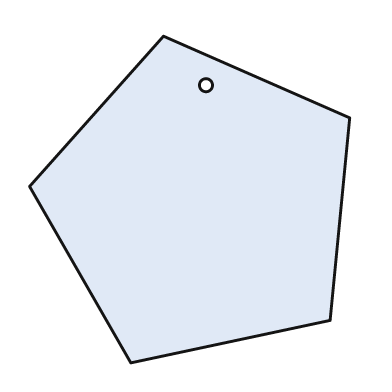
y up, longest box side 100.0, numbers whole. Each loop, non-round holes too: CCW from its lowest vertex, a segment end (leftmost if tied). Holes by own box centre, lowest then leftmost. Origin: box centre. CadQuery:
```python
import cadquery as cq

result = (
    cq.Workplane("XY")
    .moveTo(-18.0, -50.0)
    .lineTo(43.0, -37.0)
    .lineTo(49.0, 25.0)
    .lineTo(-8.0, 50.0)
    .lineTo(-49.0, 4.0)
    .close()
    .moveTo(5.0, 35.0)
    .circle(2.0)
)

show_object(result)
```